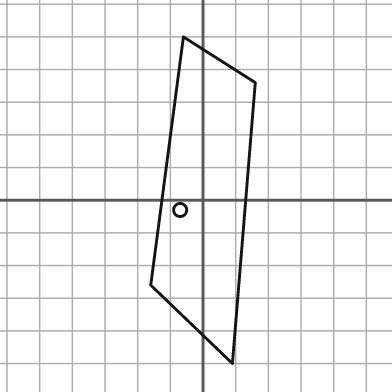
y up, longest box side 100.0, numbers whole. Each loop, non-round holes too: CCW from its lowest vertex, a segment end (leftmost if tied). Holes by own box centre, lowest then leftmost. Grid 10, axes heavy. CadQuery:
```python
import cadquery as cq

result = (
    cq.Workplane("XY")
    .moveTo(9.0, -50.0)
    .lineTo(16.0, 36.0)
    .lineTo(-6.0, 50.0)
    .lineTo(-16.0, -26.0)
    .close()
    .moveTo(-7.0, -3.0)
    .circle(2.0)
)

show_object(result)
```